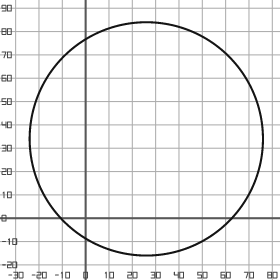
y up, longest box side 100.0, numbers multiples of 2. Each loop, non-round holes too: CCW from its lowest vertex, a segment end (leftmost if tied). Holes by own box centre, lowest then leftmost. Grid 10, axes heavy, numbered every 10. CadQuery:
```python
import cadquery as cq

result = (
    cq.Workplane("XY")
    .moveTo(26.0, 34.0)
    .circle(50.0)
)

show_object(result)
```